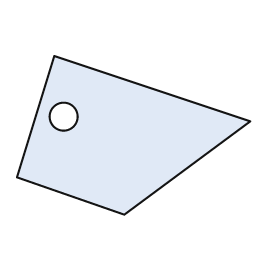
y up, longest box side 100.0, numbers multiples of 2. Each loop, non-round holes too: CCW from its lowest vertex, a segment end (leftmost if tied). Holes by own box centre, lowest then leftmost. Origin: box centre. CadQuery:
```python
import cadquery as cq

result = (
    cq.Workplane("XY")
    .moveTo(-4.0, -34.0)
    .lineTo(50.0, 6.0)
    .lineTo(-34.0, 34.0)
    .lineTo(-50.0, -18.0)
    .close()
    .moveTo(-30.0, 8.0)
    .circle(6.0)
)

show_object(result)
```